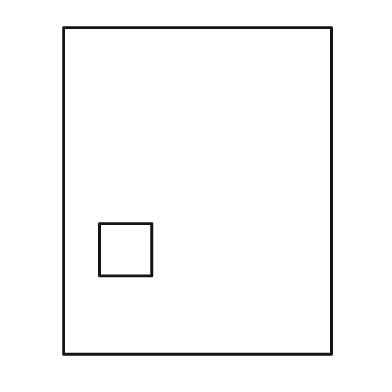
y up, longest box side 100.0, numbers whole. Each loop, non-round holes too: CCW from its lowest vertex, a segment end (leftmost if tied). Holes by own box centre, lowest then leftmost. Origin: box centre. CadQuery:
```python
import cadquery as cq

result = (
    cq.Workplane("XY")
    .moveTo(-41.0, -50.0)
    .lineTo(41.0, -50.0)
    .lineTo(41.0, 50.0)
    .lineTo(-41.0, 50.0)
    .close()
    .moveTo(-30.0, -26.0)
    .lineTo(-14.0, -26.0)
    .lineTo(-14.0, -10.0)
    .lineTo(-30.0, -10.0)
    .close()
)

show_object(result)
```